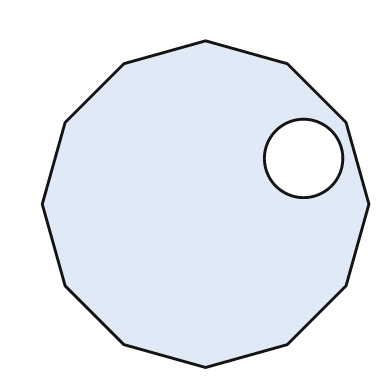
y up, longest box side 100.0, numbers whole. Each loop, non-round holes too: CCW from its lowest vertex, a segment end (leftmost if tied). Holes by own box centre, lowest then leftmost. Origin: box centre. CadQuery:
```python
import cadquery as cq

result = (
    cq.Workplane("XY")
    .moveTo(0.0, -50.0)
    .lineTo(25.0, -43.0)
    .lineTo(43.0, -25.0)
    .lineTo(50.0, 0.0)
    .lineTo(43.0, 25.0)
    .lineTo(25.0, 43.0)
    .lineTo(0.0, 50.0)
    .lineTo(-25.0, 43.0)
    .lineTo(-43.0, 25.0)
    .lineTo(-50.0, 0.0)
    .lineTo(-43.0, -25.0)
    .lineTo(-25.0, -43.0)
    .close()
    .moveTo(30.0, 14.0)
    .circle(12.0)
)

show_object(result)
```